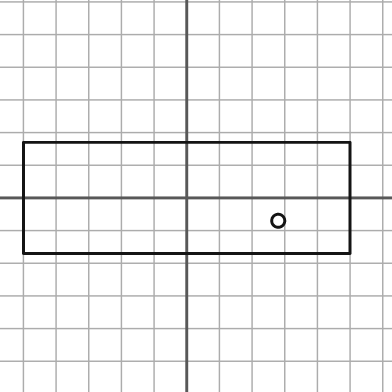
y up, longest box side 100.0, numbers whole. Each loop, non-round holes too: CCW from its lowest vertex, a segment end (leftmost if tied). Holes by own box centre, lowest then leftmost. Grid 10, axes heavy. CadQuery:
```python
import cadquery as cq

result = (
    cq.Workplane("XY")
    .moveTo(-50.0, -17.0)
    .lineTo(50.0, -17.0)
    .lineTo(50.0, 17.0)
    .lineTo(-50.0, 17.0)
    .close()
    .moveTo(28.0, -7.0)
    .circle(2.0)
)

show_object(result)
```